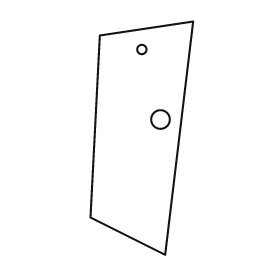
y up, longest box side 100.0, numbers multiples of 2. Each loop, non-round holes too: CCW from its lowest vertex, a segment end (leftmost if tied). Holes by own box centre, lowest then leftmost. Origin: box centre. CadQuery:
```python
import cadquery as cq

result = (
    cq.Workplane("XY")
    .moveTo(10.0, -50.0)
    .lineTo(22.0, 50.0)
    .lineTo(-18.0, 44.0)
    .lineTo(-22.0, -34.0)
    .close()
    .moveTo(8.0, 8.0)
    .circle(4.0)
    .moveTo(0.0, 38.0)
    .circle(2.0)
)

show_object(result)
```